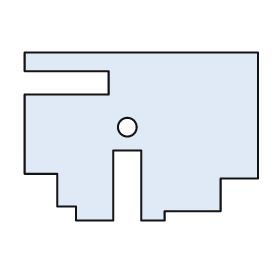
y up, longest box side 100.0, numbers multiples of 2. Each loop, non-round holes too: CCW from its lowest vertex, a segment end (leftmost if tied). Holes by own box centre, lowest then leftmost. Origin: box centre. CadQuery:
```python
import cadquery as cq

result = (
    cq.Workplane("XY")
    .moveTo(-28.0, -36.0)
    .lineTo(-12.0, -36.0)
    .lineTo(-12.0, -6.0)
    .lineTo(0.0, -6.0)
    .lineTo(0.0, -36.0)
    .lineTo(10.0, -36.0)
    .lineTo(10.0, -32.0)
    .lineTo(34.0, -32.0)
    .lineTo(34.0, -18.0)
    .lineTo(50.0, -18.0)
    .lineTo(50.0, 36.0)
    .lineTo(-50.0, 36.0)
    .lineTo(-50.0, 28.0)
    .lineTo(-14.0, 28.0)
    .lineTo(-14.0, 18.0)
    .lineTo(-50.0, 18.0)
    .lineTo(-50.0, -16.0)
    .lineTo(-36.0, -16.0)
    .lineTo(-36.0, -30.0)
    .lineTo(-28.0, -30.0)
    .close()
    .moveTo(-6.0, 4.0)
    .circle(4.0)
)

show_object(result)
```